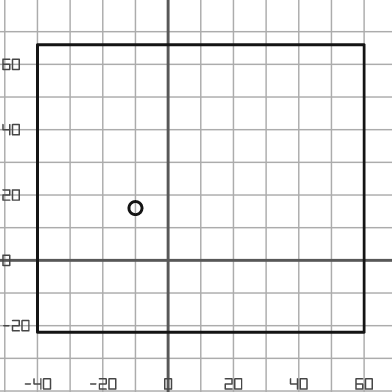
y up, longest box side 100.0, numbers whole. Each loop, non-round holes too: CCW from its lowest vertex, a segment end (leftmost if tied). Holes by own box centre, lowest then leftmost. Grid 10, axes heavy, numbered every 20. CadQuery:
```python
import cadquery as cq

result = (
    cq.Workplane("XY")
    .moveTo(-40.0, -22.0)
    .lineTo(60.0, -22.0)
    .lineTo(60.0, 66.0)
    .lineTo(-40.0, 66.0)
    .close()
    .moveTo(-10.0, 16.0)
    .circle(2.0)
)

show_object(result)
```